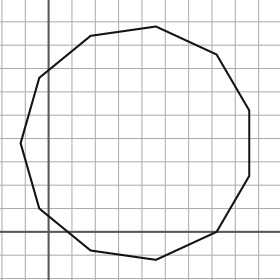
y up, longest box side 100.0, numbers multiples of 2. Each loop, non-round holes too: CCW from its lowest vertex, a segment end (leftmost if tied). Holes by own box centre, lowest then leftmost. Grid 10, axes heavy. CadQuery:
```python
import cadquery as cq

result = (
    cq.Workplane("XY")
    .moveTo(46.0, -12.0)
    .lineTo(72.0, 0.0)
    .lineTo(86.0, 24.0)
    .lineTo(86.0, 52.0)
    .lineTo(72.0, 76.0)
    .lineTo(46.0, 88.0)
    .lineTo(18.0, 84.0)
    .lineTo(-4.0, 66.0)
    .lineTo(-12.0, 38.0)
    .lineTo(-4.0, 10.0)
    .lineTo(18.0, -8.0)
    .close()
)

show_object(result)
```